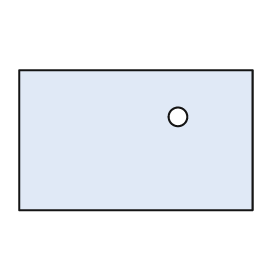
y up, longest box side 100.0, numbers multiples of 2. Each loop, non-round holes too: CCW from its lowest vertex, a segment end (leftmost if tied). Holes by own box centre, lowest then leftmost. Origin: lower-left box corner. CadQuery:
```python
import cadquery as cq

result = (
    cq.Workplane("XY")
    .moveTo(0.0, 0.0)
    .lineTo(100.0, 0.0)
    .lineTo(100.0, 60.0)
    .lineTo(0.0, 60.0)
    .close()
    .moveTo(68.0, 40.0)
    .circle(4.0)
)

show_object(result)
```